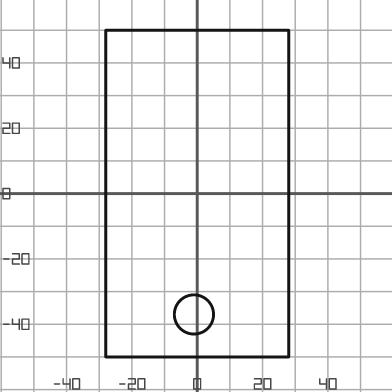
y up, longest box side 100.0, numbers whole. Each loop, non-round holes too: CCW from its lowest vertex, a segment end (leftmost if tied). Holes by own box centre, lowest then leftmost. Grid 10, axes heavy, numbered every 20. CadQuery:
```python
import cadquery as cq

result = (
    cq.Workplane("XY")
    .moveTo(-28.0, -50.0)
    .lineTo(28.0, -50.0)
    .lineTo(28.0, 50.0)
    .lineTo(-28.0, 50.0)
    .close()
    .moveTo(-1.0, -37.0)
    .circle(6.0)
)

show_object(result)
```